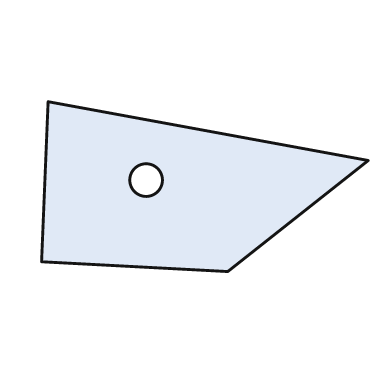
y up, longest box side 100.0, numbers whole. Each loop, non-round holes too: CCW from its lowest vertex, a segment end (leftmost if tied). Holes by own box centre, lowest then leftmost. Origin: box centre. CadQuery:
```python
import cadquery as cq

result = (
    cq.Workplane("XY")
    .moveTo(7.0, -26.0)
    .lineTo(50.0, 8.0)
    .lineTo(-48.0, 26.0)
    .lineTo(-50.0, -23.0)
    .close()
    .moveTo(-18.0, 2.0)
    .circle(5.0)
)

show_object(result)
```